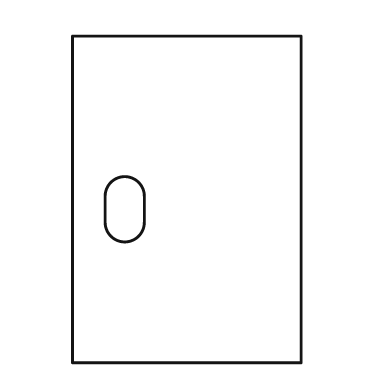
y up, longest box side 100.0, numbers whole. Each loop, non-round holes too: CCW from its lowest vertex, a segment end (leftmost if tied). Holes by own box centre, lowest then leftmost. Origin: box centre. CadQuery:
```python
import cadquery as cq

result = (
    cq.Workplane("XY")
    .moveTo(-35.0, -50.0)
    .lineTo(35.0, -50.0)
    .lineTo(35.0, 50.0)
    .lineTo(-35.0, 50.0)
    .close()
    .moveTo(-25.0, -7.0)
    .threePointArc((-19.0, -13.0), (-13.0, -7.0))
    .lineTo(-13.0, 1.0)
    .threePointArc((-19.0, 7.0), (-25.0, 1.0))
    .close()
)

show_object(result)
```